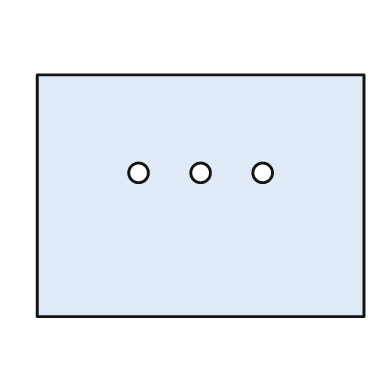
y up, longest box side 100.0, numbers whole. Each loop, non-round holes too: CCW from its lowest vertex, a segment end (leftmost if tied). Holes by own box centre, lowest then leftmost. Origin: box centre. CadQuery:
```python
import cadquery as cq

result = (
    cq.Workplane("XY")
    .moveTo(-50.0, -37.0)
    .lineTo(50.0, -37.0)
    .lineTo(50.0, 37.0)
    .lineTo(-50.0, 37.0)
    .close()
    .moveTo(-19.0, 7.0)
    .circle(3.0)
    .moveTo(0.0, 7.0)
    .circle(3.0)
    .moveTo(19.0, 7.0)
    .circle(3.0)
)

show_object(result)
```